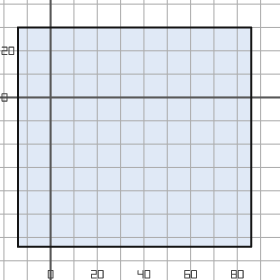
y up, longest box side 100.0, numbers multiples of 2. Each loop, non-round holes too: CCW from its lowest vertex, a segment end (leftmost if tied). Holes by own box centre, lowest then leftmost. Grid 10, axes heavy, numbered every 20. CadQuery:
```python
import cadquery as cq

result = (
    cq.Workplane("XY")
    .moveTo(-14.0, -64.0)
    .lineTo(86.0, -64.0)
    .lineTo(86.0, 30.0)
    .lineTo(-14.0, 30.0)
    .close()
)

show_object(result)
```